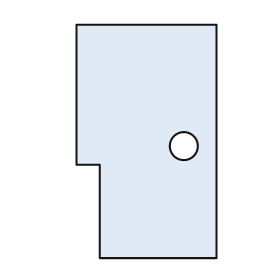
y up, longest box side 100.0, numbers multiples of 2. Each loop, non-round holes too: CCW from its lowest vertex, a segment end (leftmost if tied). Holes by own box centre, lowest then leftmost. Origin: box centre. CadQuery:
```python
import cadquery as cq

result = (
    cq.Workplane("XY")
    .moveTo(-20.0, -50.0)
    .lineTo(30.0, -50.0)
    .lineTo(30.0, 50.0)
    .lineTo(-30.0, 50.0)
    .lineTo(-30.0, -10.0)
    .lineTo(-20.0, -10.0)
    .close()
    .moveTo(16.0, -2.0)
    .circle(6.0)
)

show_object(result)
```